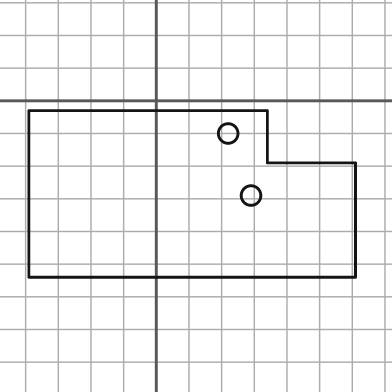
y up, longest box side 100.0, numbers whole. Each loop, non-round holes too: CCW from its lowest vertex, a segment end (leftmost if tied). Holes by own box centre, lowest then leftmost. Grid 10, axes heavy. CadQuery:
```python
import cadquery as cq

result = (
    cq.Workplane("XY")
    .moveTo(-39.0, -54.0)
    .lineTo(61.0, -54.0)
    .lineTo(61.0, -19.0)
    .lineTo(34.0, -19.0)
    .lineTo(34.0, -3.0)
    .lineTo(-39.0, -3.0)
    .close()
    .moveTo(29.0, -29.0)
    .circle(3.0)
    .moveTo(22.0, -10.0)
    .circle(3.0)
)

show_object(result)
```